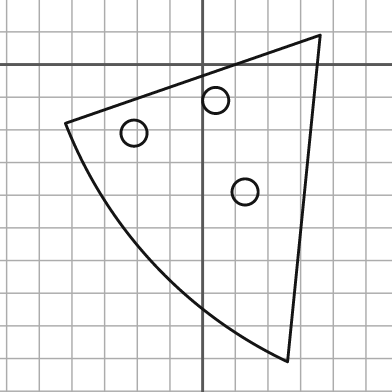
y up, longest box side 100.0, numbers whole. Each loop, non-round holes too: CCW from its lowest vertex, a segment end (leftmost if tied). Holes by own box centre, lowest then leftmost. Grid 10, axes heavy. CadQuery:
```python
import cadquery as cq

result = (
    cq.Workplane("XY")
    .moveTo(26.0, -91.0)
    .lineTo(36.0, 9.0)
    .lineTo(-42.0, -18.0)
    .threePointArc((-15.0, -61.0), (26.0, -91.0))
    .close()
    .moveTo(13.0, -39.0)
    .circle(4.0)
    .moveTo(-21.0, -21.0)
    .circle(4.0)
    .moveTo(4.0, -11.0)
    .circle(4.0)
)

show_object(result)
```